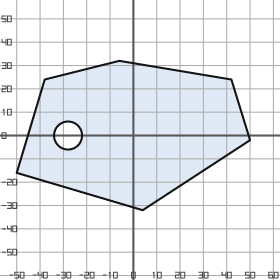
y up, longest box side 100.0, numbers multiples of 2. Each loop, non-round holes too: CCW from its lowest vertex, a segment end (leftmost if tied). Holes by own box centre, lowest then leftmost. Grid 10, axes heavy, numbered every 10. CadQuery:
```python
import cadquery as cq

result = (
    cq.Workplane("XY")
    .moveTo(4.0, -32.0)
    .lineTo(50.0, -2.0)
    .lineTo(42.0, 24.0)
    .lineTo(-6.0, 32.0)
    .lineTo(-38.0, 24.0)
    .lineTo(-50.0, -16.0)
    .close()
    .moveTo(-28.0, 0.0)
    .circle(6.0)
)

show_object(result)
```